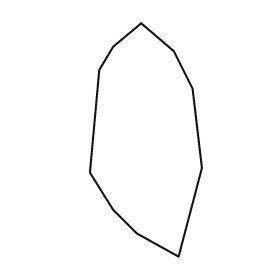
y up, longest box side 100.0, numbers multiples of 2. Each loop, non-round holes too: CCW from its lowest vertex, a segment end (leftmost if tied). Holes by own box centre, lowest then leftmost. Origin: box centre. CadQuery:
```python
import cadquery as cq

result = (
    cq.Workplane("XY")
    .moveTo(14.0, -50.0)
    .lineTo(24.0, -12.0)
    .lineTo(20.0, 22.0)
    .lineTo(12.0, 38.0)
    .lineTo(-2.0, 50.0)
    .lineTo(-14.0, 40.0)
    .lineTo(-20.0, 30.0)
    .lineTo(-24.0, -14.0)
    .lineTo(-14.0, -30.0)
    .lineTo(-4.0, -40.0)
    .close()
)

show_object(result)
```